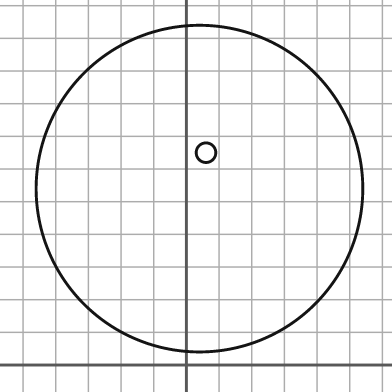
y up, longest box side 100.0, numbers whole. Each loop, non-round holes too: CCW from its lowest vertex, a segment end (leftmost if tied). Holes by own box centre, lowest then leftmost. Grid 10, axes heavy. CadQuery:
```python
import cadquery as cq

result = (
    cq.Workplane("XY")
    .moveTo(4.0, 54.0)
    .circle(50.0)
    .moveTo(6.0, 65.0)
    .circle(3.0)
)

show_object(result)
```